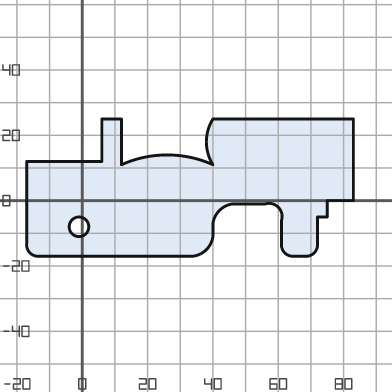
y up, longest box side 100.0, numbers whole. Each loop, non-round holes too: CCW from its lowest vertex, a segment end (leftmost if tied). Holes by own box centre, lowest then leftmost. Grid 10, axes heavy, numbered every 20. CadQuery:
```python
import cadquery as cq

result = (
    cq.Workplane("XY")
    .moveTo(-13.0, -17.0)
    .lineTo(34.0, -17.0)
    .threePointArc((38.0, -15.0), (40.0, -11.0))
    .lineTo(40.0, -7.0)
    .threePointArc((42.0, -3.0), (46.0, -1.0))
    .lineTo(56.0, -1.0)
    .threePointArc((60.0, -2.0), (61.0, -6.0))
    .lineTo(61.0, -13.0)
    .threePointArc((62.0, -16.0), (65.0, -17.0))
    .lineTo(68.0, -17.0)
    .threePointArc((71.0, -16.0), (72.0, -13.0))
    .lineTo(72.0, -5.0)
    .lineTo(75.0, -5.0)
    .lineTo(75.0, 0.0)
    .lineTo(83.0, 0.0)
    .lineTo(83.0, 25.0)
    .lineTo(40.0, 25.0)
    .threePointArc((38.0, 18.0), (40.0, 11.0))
    .threePointArc((26.0, 14.0), (12.0, 11.0))
    .lineTo(12.0, 25.0)
    .lineTo(6.0, 25.0)
    .lineTo(6.0, 12.0)
    .lineTo(-17.0, 12.0)
    .lineTo(-17.0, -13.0)
    .threePointArc((-16.0, -16.0), (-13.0, -17.0))
    .close()
    .moveTo(-1.0, -8.0)
    .circle(3.0)
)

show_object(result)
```